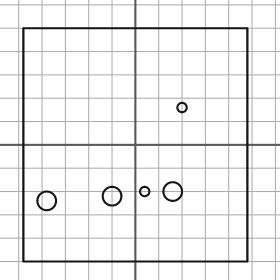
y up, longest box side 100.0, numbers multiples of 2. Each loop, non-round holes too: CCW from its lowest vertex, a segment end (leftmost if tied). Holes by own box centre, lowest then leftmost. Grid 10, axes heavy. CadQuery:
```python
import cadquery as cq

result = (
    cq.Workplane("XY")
    .moveTo(-48.0, -50.0)
    .lineTo(48.0, -50.0)
    .lineTo(48.0, 50.0)
    .lineTo(-48.0, 50.0)
    .close()
    .moveTo(-38.0, -24.0)
    .circle(4.0)
    .moveTo(-10.0, -22.0)
    .circle(4.0)
    .moveTo(4.0, -20.0)
    .circle(2.0)
    .moveTo(16.0, -20.0)
    .circle(4.0)
    .moveTo(20.0, 16.0)
    .circle(2.0)
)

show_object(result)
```